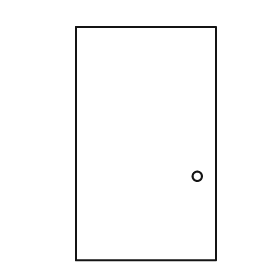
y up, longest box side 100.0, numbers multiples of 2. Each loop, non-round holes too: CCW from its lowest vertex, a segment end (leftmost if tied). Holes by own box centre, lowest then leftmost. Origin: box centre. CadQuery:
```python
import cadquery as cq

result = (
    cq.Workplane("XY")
    .moveTo(-30.0, -50.0)
    .lineTo(30.0, -50.0)
    .lineTo(30.0, 50.0)
    .lineTo(-30.0, 50.0)
    .close()
    .moveTo(22.0, -14.0)
    .circle(2.0)
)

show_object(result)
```